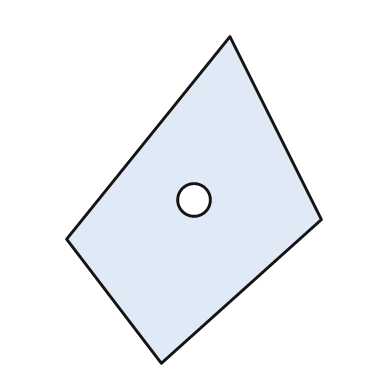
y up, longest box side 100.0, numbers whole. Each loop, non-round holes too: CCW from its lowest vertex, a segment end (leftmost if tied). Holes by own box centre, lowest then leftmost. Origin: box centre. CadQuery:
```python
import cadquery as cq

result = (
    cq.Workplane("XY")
    .moveTo(-10.0, -50.0)
    .lineTo(39.0, -6.0)
    .lineTo(11.0, 50.0)
    .lineTo(-39.0, -12.0)
    .close()
    .moveTo(0.0, 0.0)
    .circle(5.0)
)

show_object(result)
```